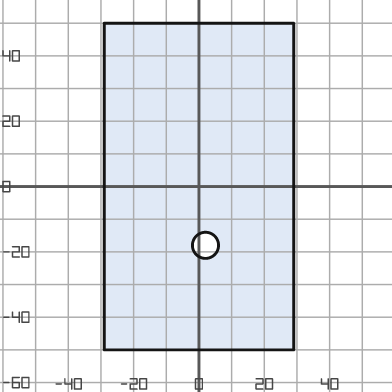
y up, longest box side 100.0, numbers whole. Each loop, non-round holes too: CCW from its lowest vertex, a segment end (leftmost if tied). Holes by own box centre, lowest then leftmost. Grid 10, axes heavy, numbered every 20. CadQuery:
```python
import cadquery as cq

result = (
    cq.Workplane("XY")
    .moveTo(-29.0, -50.0)
    .lineTo(29.0, -50.0)
    .lineTo(29.0, 50.0)
    .lineTo(-29.0, 50.0)
    .close()
    .moveTo(2.0, -18.0)
    .circle(4.0)
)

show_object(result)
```